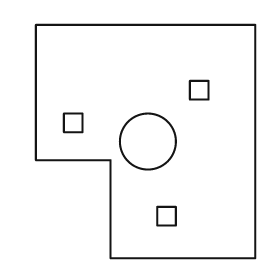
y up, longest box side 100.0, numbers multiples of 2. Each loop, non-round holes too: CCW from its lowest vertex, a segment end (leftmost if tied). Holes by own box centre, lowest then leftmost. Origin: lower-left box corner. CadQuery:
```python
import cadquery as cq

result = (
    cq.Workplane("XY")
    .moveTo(32.0, 0.0)
    .lineTo(94.0, 0.0)
    .lineTo(94.0, 100.0)
    .lineTo(0.0, 100.0)
    .lineTo(0.0, 42.0)
    .lineTo(32.0, 42.0)
    .close()
    .moveTo(52.0, 14.0)
    .lineTo(60.0, 14.0)
    .lineTo(60.0, 22.0)
    .lineTo(52.0, 22.0)
    .close()
    .moveTo(48.0, 50.0)
    .circle(12.0)
    .moveTo(12.0, 54.0)
    .lineTo(20.0, 54.0)
    .lineTo(20.0, 62.0)
    .lineTo(12.0, 62.0)
    .close()
    .moveTo(66.0, 68.0)
    .lineTo(74.0, 68.0)
    .lineTo(74.0, 76.0)
    .lineTo(66.0, 76.0)
    .close()
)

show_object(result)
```